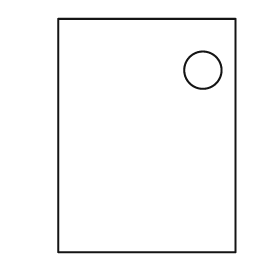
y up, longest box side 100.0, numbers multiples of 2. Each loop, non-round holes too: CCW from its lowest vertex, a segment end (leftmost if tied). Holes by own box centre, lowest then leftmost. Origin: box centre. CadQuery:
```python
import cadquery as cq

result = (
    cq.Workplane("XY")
    .moveTo(-38.0, -50.0)
    .lineTo(38.0, -50.0)
    .lineTo(38.0, 50.0)
    .lineTo(-38.0, 50.0)
    .close()
    .moveTo(24.0, 28.0)
    .circle(8.0)
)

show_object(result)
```